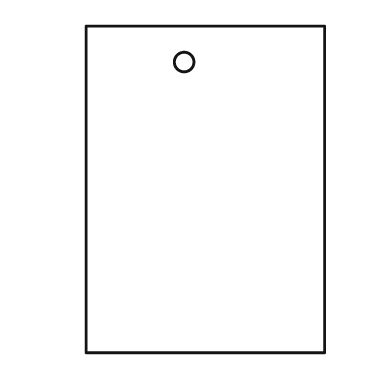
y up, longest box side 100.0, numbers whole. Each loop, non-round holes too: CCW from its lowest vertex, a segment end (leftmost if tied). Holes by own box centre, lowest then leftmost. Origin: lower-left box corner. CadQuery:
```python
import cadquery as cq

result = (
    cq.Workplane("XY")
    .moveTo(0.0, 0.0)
    .lineTo(73.0, 0.0)
    .lineTo(73.0, 100.0)
    .lineTo(0.0, 100.0)
    .close()
    .moveTo(30.0, 89.0)
    .circle(3.0)
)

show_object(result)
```